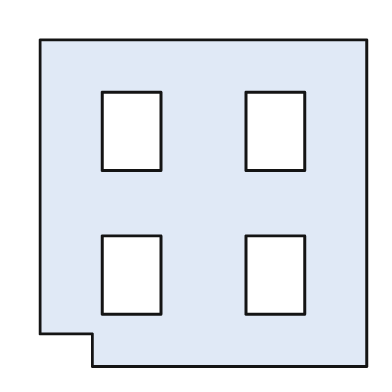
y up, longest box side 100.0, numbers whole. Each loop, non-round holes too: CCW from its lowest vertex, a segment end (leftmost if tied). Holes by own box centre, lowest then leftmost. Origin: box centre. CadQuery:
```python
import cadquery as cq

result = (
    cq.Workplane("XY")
    .moveTo(-34.0, -50.0)
    .lineTo(50.0, -50.0)
    .lineTo(50.0, 50.0)
    .lineTo(-50.0, 50.0)
    .lineTo(-50.0, -40.0)
    .lineTo(-34.0, -40.0)
    .close()
    .moveTo(-31.0, -34.0)
    .lineTo(-13.0, -34.0)
    .lineTo(-13.0, -10.0)
    .lineTo(-31.0, -10.0)
    .close()
    .moveTo(13.0, -34.0)
    .lineTo(31.0, -34.0)
    .lineTo(31.0, -10.0)
    .lineTo(13.0, -10.0)
    .close()
    .moveTo(-31.0, 10.0)
    .lineTo(-13.0, 10.0)
    .lineTo(-13.0, 34.0)
    .lineTo(-31.0, 34.0)
    .close()
    .moveTo(13.0, 10.0)
    .lineTo(31.0, 10.0)
    .lineTo(31.0, 34.0)
    .lineTo(13.0, 34.0)
    .close()
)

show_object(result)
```